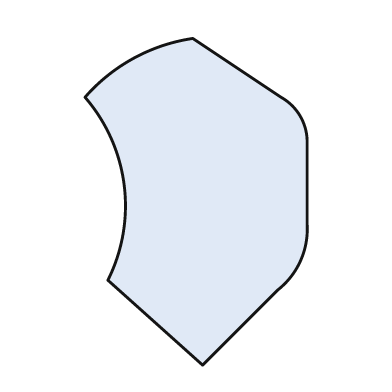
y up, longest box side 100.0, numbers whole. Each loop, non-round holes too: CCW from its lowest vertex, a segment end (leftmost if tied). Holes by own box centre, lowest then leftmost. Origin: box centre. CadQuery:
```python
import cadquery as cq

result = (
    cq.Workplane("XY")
    .moveTo(2.0, -50.0)
    .lineTo(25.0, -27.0)
    .threePointArc((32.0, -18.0), (34.0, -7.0))
    .lineTo(34.0, 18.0)
    .threePointArc((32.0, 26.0), (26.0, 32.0))
    .lineTo(-1.0, 50.0)
    .threePointArc((-19.0, 44.0), (-34.0, 32.0))
    .threePointArc((-22.0, 5.0), (-27.0, -24.0))
    .close()
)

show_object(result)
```